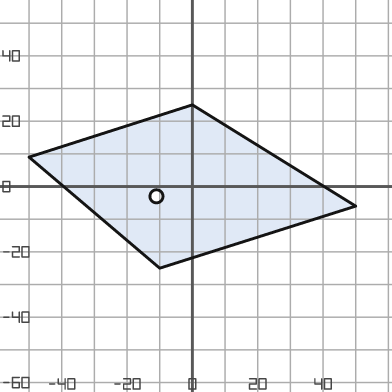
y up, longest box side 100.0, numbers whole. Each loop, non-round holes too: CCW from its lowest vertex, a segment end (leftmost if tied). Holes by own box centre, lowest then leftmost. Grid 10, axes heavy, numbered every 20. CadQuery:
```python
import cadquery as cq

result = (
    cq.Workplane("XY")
    .moveTo(-10.0, -25.0)
    .lineTo(50.0, -6.0)
    .lineTo(0.0, 25.0)
    .lineTo(-50.0, 9.0)
    .close()
    .moveTo(-11.0, -3.0)
    .circle(2.0)
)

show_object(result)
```